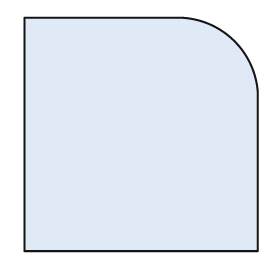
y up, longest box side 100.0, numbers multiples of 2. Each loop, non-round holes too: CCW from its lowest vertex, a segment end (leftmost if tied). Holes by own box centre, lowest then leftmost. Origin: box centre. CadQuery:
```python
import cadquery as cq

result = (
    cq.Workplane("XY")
    .moveTo(-50.0, -50.0)
    .lineTo(50.0, -50.0)
    .lineTo(50.0, 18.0)
    .threePointArc((40.0, 40.0), (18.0, 50.0))
    .lineTo(-50.0, 50.0)
    .close()
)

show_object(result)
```